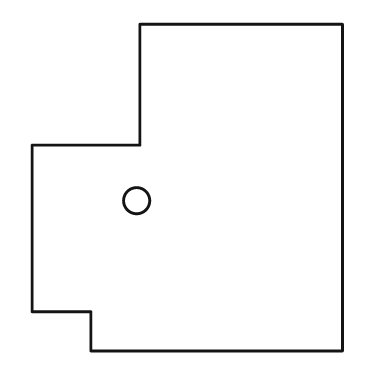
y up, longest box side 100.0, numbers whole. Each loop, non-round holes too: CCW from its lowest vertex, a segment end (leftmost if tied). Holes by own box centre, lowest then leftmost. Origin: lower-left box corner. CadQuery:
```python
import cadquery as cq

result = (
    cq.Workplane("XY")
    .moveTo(18.0, 0.0)
    .lineTo(95.0, 0.0)
    .lineTo(95.0, 100.0)
    .lineTo(33.0, 100.0)
    .lineTo(33.0, 63.0)
    .lineTo(0.0, 63.0)
    .lineTo(0.0, 12.0)
    .lineTo(18.0, 12.0)
    .close()
    .moveTo(32.0, 46.0)
    .circle(4.0)
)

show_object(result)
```